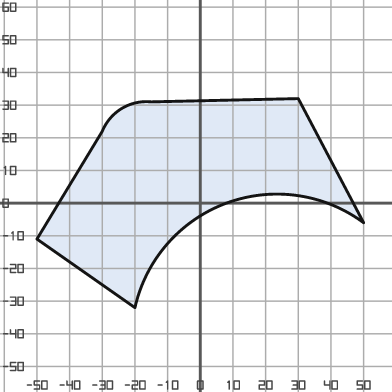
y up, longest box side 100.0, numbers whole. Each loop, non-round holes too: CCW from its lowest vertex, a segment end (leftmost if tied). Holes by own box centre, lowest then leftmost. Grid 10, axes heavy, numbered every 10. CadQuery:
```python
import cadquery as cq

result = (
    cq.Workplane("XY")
    .moveTo(-20.0, -32.0)
    .threePointArc((8.0, 0.0), (50.0, -6.0))
    .lineTo(30.0, 32.0)
    .lineTo(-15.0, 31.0)
    .threePointArc((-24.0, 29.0), (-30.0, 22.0))
    .lineTo(-50.0, -11.0)
    .close()
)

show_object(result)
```